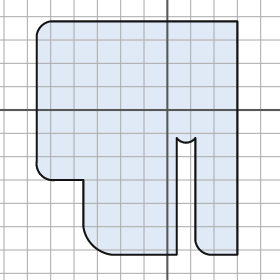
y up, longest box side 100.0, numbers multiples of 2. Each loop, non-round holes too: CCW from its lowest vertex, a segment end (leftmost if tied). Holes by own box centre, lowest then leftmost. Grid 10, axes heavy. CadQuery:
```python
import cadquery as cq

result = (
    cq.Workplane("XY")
    .moveTo(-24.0, -62.0)
    .lineTo(4.0, -62.0)
    .lineTo(4.0, -12.0)
    .threePointArc((8.0, -14.0), (12.0, -12.0))
    .lineTo(12.0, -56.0)
    .threePointArc((14.0, -60.0), (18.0, -62.0))
    .lineTo(30.0, -62.0)
    .lineTo(30.0, 38.0)
    .lineTo(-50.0, 38.0)
    .threePointArc((-54.0, 36.0), (-56.0, 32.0))
    .lineTo(-56.0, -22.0)
    .threePointArc((-54.0, -28.0), (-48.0, -30.0))
    .lineTo(-36.0, -30.0)
    .lineTo(-36.0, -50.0)
    .threePointArc((-32.0, -58.0), (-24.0, -62.0))
    .close()
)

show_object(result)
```